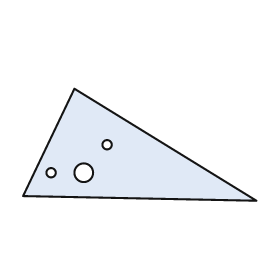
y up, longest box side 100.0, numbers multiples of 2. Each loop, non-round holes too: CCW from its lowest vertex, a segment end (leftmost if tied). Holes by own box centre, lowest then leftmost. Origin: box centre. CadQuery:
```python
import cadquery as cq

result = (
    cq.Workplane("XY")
    .moveTo(50.0, -24.0)
    .lineTo(-28.0, 24.0)
    .lineTo(-50.0, -22.0)
    .close()
    .moveTo(-38.0, -12.0)
    .circle(2.0)
    .moveTo(-24.0, -12.0)
    .circle(4.0)
    .moveTo(-14.0, 0.0)
    .circle(2.0)
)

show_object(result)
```